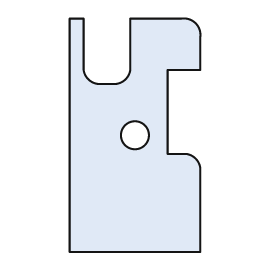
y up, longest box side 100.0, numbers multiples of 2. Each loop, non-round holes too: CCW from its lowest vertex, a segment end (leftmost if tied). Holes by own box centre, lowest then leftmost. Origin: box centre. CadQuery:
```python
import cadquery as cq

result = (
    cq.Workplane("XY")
    .moveTo(-28.0, -50.0)
    .lineTo(28.0, -50.0)
    .lineTo(28.0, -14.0)
    .threePointArc((26.0, -10.0), (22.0, -8.0))
    .lineTo(14.0, -8.0)
    .lineTo(14.0, 28.0)
    .lineTo(28.0, 28.0)
    .lineTo(28.0, 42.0)
    .threePointArc((26.0, 48.0), (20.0, 50.0))
    .lineTo(-2.0, 50.0)
    .lineTo(-2.0, 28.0)
    .threePointArc((-4.0, 24.0), (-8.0, 22.0))
    .lineTo(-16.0, 22.0)
    .threePointArc((-20.0, 24.0), (-22.0, 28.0))
    .lineTo(-22.0, 50.0)
    .lineTo(-28.0, 50.0)
    .close()
    .moveTo(0.0, 0.0)
    .circle(6.0)
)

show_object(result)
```